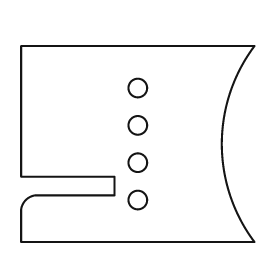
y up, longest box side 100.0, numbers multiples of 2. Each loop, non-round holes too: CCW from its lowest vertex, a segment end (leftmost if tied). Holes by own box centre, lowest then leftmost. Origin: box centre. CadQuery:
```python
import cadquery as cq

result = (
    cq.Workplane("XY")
    .moveTo(-50.0, -42.0)
    .lineTo(50.0, -42.0)
    .threePointArc((36.0, 0.0), (50.0, 42.0))
    .lineTo(-50.0, 42.0)
    .lineTo(-50.0, -14.0)
    .lineTo(-10.0, -14.0)
    .lineTo(-10.0, -22.0)
    .lineTo(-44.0, -22.0)
    .threePointArc((-48.0, -24.0), (-50.0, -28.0))
    .close()
    .moveTo(0.0, -24.0)
    .circle(4.0)
    .moveTo(0.0, -8.0)
    .circle(4.0)
    .moveTo(0.0, 8.0)
    .circle(4.0)
    .moveTo(0.0, 24.0)
    .circle(4.0)
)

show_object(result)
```